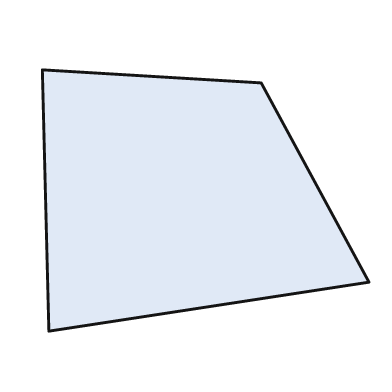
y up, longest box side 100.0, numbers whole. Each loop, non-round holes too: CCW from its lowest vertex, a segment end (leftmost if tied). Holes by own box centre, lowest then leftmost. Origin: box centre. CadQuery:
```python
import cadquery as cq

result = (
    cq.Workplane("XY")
    .moveTo(-48.0, -40.0)
    .lineTo(50.0, -25.0)
    .lineTo(17.0, 36.0)
    .lineTo(-50.0, 40.0)
    .close()
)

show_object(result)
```